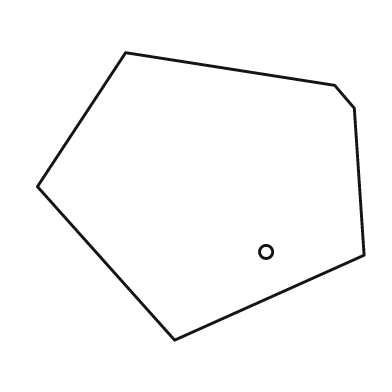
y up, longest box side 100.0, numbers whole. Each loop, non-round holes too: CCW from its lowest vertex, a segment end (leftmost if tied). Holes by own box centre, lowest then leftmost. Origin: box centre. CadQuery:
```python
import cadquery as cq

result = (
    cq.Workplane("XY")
    .moveTo(-8.0, -44.0)
    .lineTo(50.0, -18.0)
    .lineTo(47.0, 27.0)
    .lineTo(41.0, 34.0)
    .lineTo(-23.0, 44.0)
    .lineTo(-50.0, 3.0)
    .close()
    .moveTo(20.0, -17.0)
    .circle(2.0)
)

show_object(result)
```